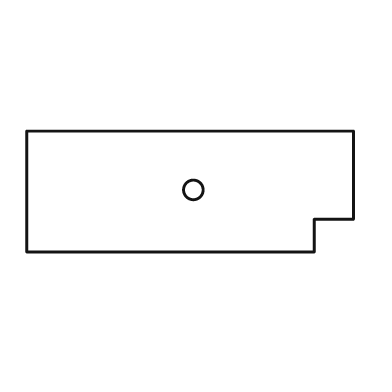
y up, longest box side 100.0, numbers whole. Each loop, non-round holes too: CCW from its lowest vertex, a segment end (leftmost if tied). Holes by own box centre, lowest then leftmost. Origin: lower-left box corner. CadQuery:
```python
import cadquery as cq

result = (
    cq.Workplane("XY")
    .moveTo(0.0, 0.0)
    .lineTo(88.0, 0.0)
    .lineTo(88.0, 10.0)
    .lineTo(100.0, 10.0)
    .lineTo(100.0, 37.0)
    .lineTo(0.0, 37.0)
    .close()
    .moveTo(51.0, 19.0)
    .circle(3.0)
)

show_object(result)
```